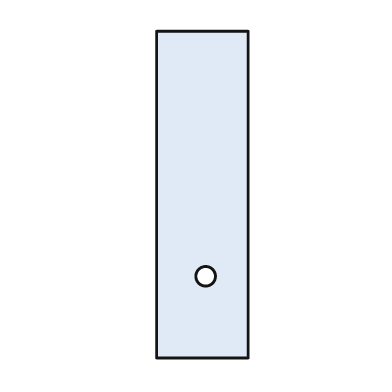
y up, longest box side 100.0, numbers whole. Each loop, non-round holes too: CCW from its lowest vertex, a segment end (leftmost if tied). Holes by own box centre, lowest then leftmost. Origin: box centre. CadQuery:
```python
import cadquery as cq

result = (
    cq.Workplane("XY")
    .moveTo(-14.0, -50.0)
    .lineTo(14.0, -50.0)
    .lineTo(14.0, 50.0)
    .lineTo(-14.0, 50.0)
    .close()
    .moveTo(1.0, -25.0)
    .circle(3.0)
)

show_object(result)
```